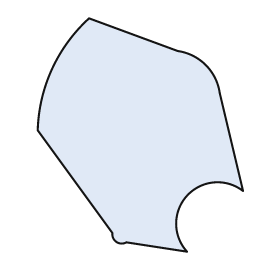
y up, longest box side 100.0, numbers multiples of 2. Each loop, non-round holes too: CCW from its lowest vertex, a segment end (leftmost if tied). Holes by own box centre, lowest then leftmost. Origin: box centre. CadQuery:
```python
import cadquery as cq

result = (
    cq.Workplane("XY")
    .moveTo(20.0, -50.0)
    .threePointArc((20.0, -26.0), (44.0, -24.0))
    .lineTo(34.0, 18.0)
    .threePointArc((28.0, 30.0), (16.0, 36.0))
    .lineTo(-22.0, 50.0)
    .threePointArc((-38.0, 28.0), (-44.0, 2.0))
    .lineTo(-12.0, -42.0)
    .threePointArc((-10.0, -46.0), (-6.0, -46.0))
    .close()
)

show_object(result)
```